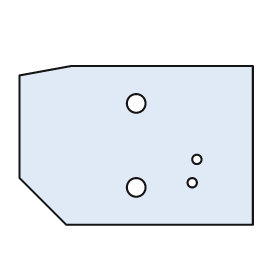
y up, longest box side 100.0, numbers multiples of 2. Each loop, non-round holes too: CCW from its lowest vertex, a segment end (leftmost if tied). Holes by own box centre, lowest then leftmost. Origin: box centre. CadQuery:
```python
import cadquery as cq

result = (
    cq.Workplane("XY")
    .moveTo(-30.0, -34.0)
    .lineTo(50.0, -34.0)
    .lineTo(50.0, 34.0)
    .lineTo(-28.0, 34.0)
    .lineTo(-50.0, 30.0)
    .lineTo(-50.0, -14.0)
    .close()
    .moveTo(0.0, -18.0)
    .circle(4.0)
    .moveTo(24.0, -16.0)
    .circle(2.0)
    .moveTo(26.0, -6.0)
    .circle(2.0)
    .moveTo(0.0, 18.0)
    .circle(4.0)
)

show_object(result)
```